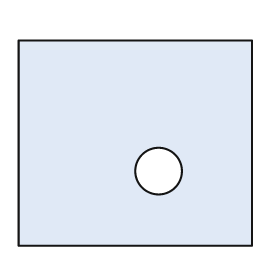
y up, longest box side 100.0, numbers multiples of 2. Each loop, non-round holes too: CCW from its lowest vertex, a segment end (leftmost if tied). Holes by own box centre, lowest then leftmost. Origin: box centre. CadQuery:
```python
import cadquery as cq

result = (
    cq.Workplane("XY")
    .moveTo(-50.0, -44.0)
    .lineTo(50.0, -44.0)
    .lineTo(50.0, 44.0)
    .lineTo(-50.0, 44.0)
    .close()
    .moveTo(10.0, -12.0)
    .circle(10.0)
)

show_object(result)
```